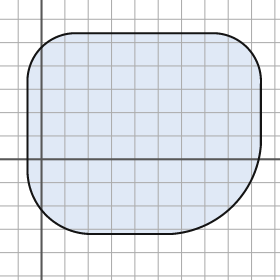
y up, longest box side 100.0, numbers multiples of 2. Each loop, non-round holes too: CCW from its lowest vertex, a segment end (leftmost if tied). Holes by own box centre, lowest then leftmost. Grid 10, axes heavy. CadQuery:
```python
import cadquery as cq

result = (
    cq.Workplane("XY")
    .moveTo(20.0, -32.0)
    .lineTo(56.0, -32.0)
    .threePointArc((82.0, -20.0), (94.0, 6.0))
    .lineTo(94.0, 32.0)
    .threePointArc((88.0, 48.0), (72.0, 54.0))
    .lineTo(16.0, 54.0)
    .threePointArc((0.0, 48.0), (-6.0, 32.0))
    .lineTo(-6.0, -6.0)
    .threePointArc((2.0, -24.0), (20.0, -32.0))
    .close()
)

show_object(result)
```